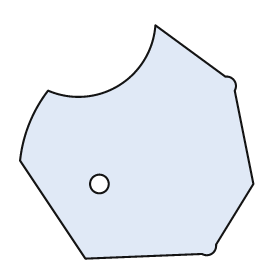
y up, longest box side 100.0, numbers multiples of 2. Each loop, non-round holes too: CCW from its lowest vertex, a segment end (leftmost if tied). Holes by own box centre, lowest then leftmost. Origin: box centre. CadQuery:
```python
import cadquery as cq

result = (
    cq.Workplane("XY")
    .moveTo(-22.0, -50.0)
    .lineTo(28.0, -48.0)
    .threePointArc((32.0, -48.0), (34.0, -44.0))
    .lineTo(50.0, -18.0)
    .lineTo(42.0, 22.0)
    .threePointArc((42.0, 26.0), (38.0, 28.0))
    .lineTo(8.0, 50.0)
    .threePointArc((-8.0, 24.0), (-38.0, 22.0))
    .threePointArc((-46.0, 8.0), (-50.0, -8.0))
    .close()
    .moveTo(-16.0, -18.0)
    .circle(4.0)
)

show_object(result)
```